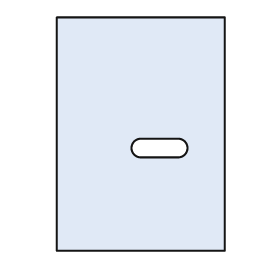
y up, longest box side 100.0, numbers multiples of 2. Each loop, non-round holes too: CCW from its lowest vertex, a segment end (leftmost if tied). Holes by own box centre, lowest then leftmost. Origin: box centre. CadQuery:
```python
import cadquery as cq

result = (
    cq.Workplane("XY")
    .moveTo(-36.0, -50.0)
    .lineTo(36.0, -50.0)
    .lineTo(36.0, 50.0)
    .lineTo(-36.0, 50.0)
    .close()
    .moveTo(0.0, -10.0)
    .lineTo(16.0, -10.0)
    .threePointArc((20.0, -6.0), (16.0, -2.0))
    .lineTo(0.0, -2.0)
    .threePointArc((-4.0, -6.0), (0.0, -10.0))
    .close()
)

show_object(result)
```